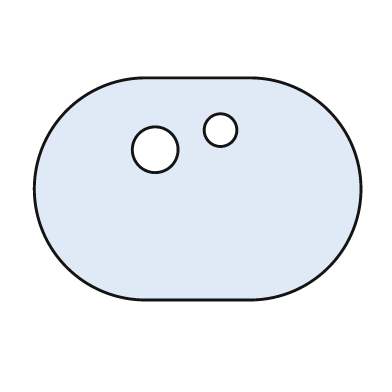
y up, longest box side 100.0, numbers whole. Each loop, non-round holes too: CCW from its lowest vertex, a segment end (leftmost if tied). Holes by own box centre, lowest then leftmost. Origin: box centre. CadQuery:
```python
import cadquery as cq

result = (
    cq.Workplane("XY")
    .moveTo(-16.0, -34.0)
    .lineTo(16.0, -34.0)
    .threePointArc((50.0, 0.0), (16.0, 34.0))
    .lineTo(-16.0, 34.0)
    .threePointArc((-50.0, 0.0), (-16.0, -34.0))
    .close()
    .moveTo(-13.0, 12.0)
    .circle(7.0)
    .moveTo(7.0, 18.0)
    .circle(5.0)
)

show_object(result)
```